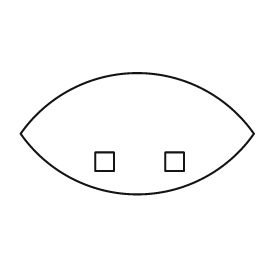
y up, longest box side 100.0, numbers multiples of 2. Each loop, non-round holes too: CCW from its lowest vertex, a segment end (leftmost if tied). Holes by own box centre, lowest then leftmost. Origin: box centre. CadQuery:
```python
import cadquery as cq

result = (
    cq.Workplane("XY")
    .moveTo(-50.0, 0.0)
    .threePointArc((0.0, -26.0), (50.0, 0.0))
    .threePointArc((0.0, 26.0), (-50.0, 0.0))
    .close()
    .moveTo(-18.0, -16.0)
    .lineTo(-10.0, -16.0)
    .lineTo(-10.0, -8.0)
    .lineTo(-18.0, -8.0)
    .close()
    .moveTo(12.0, -16.0)
    .lineTo(20.0, -16.0)
    .lineTo(20.0, -8.0)
    .lineTo(12.0, -8.0)
    .close()
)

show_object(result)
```